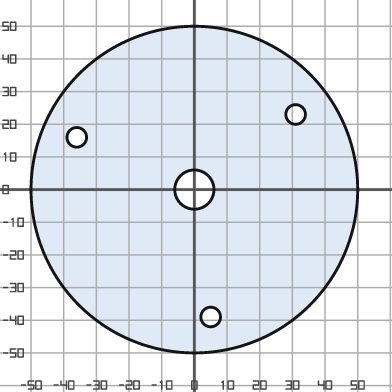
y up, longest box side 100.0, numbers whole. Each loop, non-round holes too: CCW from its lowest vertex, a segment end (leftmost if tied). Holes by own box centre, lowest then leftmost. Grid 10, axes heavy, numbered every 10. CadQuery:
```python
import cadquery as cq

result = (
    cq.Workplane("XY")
    .moveTo(0.0, 0.0)
    .circle(50.0)
    .moveTo(5.0, -39.0)
    .circle(3.0)
    .moveTo(0.0, 0.0)
    .circle(6.0)
    .moveTo(-36.0, 16.0)
    .circle(3.0)
    .moveTo(31.0, 23.0)
    .circle(3.0)
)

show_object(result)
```